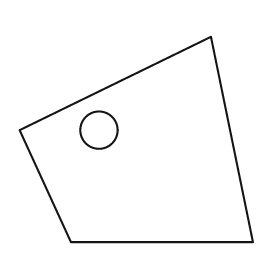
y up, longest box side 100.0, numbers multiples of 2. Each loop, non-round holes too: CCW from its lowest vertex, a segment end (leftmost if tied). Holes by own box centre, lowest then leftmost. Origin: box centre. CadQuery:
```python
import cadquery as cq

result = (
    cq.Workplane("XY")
    .moveTo(-28.0, -44.0)
    .lineTo(50.0, -44.0)
    .lineTo(32.0, 44.0)
    .lineTo(-50.0, 4.0)
    .close()
    .moveTo(-16.0, 4.0)
    .circle(8.0)
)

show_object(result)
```